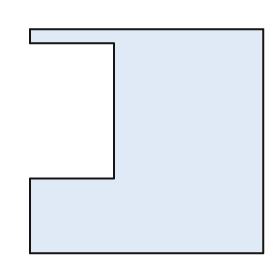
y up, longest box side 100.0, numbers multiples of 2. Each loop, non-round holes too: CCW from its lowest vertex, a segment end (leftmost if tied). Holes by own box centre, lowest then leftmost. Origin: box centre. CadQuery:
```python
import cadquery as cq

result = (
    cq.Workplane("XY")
    .moveTo(-50.0, -48.0)
    .lineTo(50.0, -48.0)
    .lineTo(50.0, 48.0)
    .lineTo(-50.0, 48.0)
    .lineTo(-50.0, 42.0)
    .lineTo(-14.0, 42.0)
    .lineTo(-14.0, -16.0)
    .lineTo(-50.0, -16.0)
    .close()
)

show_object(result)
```